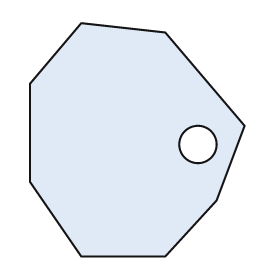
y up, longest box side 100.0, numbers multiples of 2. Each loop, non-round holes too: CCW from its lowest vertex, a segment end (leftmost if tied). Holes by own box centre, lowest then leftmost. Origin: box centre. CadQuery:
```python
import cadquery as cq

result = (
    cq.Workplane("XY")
    .moveTo(-24.0, -50.0)
    .lineTo(12.0, -50.0)
    .lineTo(34.0, -26.0)
    .lineTo(46.0, 6.0)
    .lineTo(12.0, 46.0)
    .lineTo(-24.0, 50.0)
    .lineTo(-46.0, 24.0)
    .lineTo(-46.0, -18.0)
    .close()
    .moveTo(26.0, -2.0)
    .circle(8.0)
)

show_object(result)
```